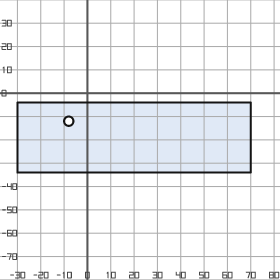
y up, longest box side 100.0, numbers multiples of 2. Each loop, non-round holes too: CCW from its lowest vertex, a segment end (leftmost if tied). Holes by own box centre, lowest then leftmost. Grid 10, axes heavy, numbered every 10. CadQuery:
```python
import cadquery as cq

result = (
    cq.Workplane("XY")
    .moveTo(-30.0, -34.0)
    .lineTo(70.0, -34.0)
    .lineTo(70.0, -4.0)
    .lineTo(-30.0, -4.0)
    .close()
    .moveTo(-8.0, -12.0)
    .circle(2.0)
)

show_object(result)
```